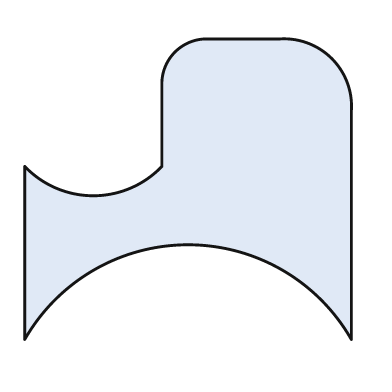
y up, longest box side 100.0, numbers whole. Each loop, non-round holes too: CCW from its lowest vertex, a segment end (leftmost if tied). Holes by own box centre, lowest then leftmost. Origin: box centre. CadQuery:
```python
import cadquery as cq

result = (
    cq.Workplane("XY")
    .moveTo(-50.0, -46.0)
    .threePointArc((0.0, -17.0), (50.0, -46.0))
    .lineTo(50.0, 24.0)
    .threePointArc((44.0, 40.0), (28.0, 46.0))
    .lineTo(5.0, 46.0)
    .threePointArc((-4.0, 42.0), (-8.0, 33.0))
    .lineTo(-8.0, 7.0)
    .threePointArc((-29.0, -2.0), (-50.0, 7.0))
    .close()
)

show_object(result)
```